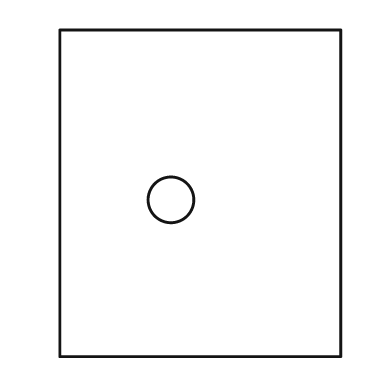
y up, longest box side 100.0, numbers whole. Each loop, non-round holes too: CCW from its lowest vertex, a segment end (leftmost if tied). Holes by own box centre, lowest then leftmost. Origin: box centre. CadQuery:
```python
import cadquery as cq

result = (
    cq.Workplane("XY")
    .moveTo(-43.0, -50.0)
    .lineTo(43.0, -50.0)
    .lineTo(43.0, 50.0)
    .lineTo(-43.0, 50.0)
    .close()
    .moveTo(-9.0, -2.0)
    .circle(7.0)
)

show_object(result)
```